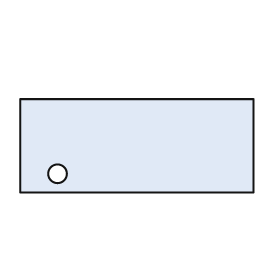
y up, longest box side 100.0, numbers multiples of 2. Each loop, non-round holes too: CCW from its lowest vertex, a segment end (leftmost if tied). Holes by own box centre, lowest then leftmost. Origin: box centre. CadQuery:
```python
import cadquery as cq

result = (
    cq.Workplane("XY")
    .moveTo(-50.0, -20.0)
    .lineTo(50.0, -20.0)
    .lineTo(50.0, 20.0)
    .lineTo(-50.0, 20.0)
    .close()
    .moveTo(-34.0, -12.0)
    .circle(4.0)
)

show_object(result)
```